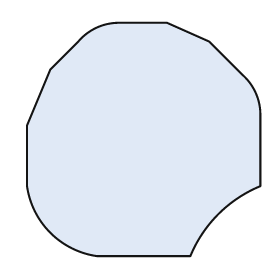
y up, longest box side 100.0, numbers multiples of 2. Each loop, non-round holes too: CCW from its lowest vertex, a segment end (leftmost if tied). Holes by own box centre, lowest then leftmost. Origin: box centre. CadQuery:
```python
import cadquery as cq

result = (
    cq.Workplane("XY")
    .moveTo(-20.0, -50.0)
    .lineTo(20.0, -50.0)
    .threePointArc((32.0, -32.0), (50.0, -20.0))
    .lineTo(50.0, 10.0)
    .threePointArc((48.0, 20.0), (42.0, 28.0))
    .lineTo(28.0, 42.0)
    .lineTo(10.0, 50.0)
    .lineTo(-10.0, 50.0)
    .threePointArc((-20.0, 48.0), (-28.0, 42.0))
    .lineTo(-40.0, 30.0)
    .lineTo(-50.0, 6.0)
    .lineTo(-50.0, -20.0)
    .threePointArc((-40.0, -40.0), (-20.0, -50.0))
    .close()
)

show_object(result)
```